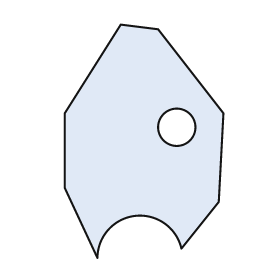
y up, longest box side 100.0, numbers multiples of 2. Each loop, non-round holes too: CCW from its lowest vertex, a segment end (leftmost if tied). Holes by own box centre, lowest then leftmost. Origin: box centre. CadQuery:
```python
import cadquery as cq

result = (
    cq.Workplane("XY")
    .moveTo(-20.0, -50.0)
    .threePointArc((-4.0, -32.0), (16.0, -46.0))
    .lineTo(32.0, -26.0)
    .lineTo(34.0, 12.0)
    .lineTo(6.0, 48.0)
    .lineTo(-10.0, 50.0)
    .lineTo(-34.0, 12.0)
    .lineTo(-34.0, -20.0)
    .close()
    .moveTo(14.0, 6.0)
    .circle(8.0)
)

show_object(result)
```